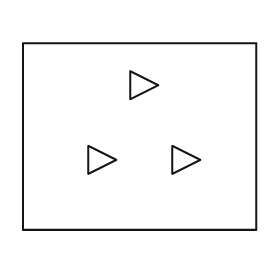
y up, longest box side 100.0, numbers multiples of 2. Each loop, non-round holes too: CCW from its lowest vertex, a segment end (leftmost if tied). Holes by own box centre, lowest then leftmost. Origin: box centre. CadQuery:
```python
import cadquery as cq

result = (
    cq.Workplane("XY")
    .moveTo(-50.0, -40.0)
    .lineTo(50.0, -40.0)
    .lineTo(50.0, 40.0)
    .lineTo(-50.0, 40.0)
    .close()
    .moveTo(-22.0, -16.0)
    .lineTo(-10.0, -10.0)
    .lineTo(-22.0, -4.0)
    .close()
    .moveTo(14.0, -16.0)
    .lineTo(26.0, -10.0)
    .lineTo(14.0, -4.0)
    .close()
    .moveTo(-4.0, 16.0)
    .lineTo(8.0, 22.0)
    .lineTo(-4.0, 28.0)
    .close()
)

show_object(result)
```